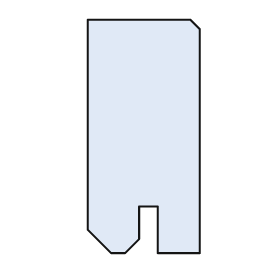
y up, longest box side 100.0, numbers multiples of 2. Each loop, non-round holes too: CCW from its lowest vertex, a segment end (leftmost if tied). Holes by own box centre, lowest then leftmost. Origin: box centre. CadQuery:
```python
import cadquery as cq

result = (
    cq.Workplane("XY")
    .moveTo(-14.0, -50.0)
    .lineTo(-8.0, -50.0)
    .lineTo(-2.0, -44.0)
    .lineTo(-2.0, -30.0)
    .lineTo(6.0, -30.0)
    .lineTo(6.0, -50.0)
    .lineTo(24.0, -50.0)
    .lineTo(24.0, 46.0)
    .lineTo(20.0, 50.0)
    .lineTo(-24.0, 50.0)
    .lineTo(-24.0, -40.0)
    .close()
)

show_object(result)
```